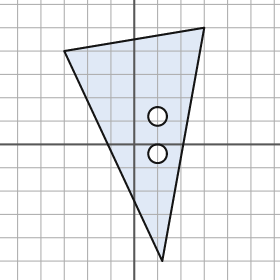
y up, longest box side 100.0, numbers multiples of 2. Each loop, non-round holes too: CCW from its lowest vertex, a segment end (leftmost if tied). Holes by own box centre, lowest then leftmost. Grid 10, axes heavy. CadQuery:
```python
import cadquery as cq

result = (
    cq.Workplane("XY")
    .moveTo(12.0, -50.0)
    .lineTo(30.0, 50.0)
    .lineTo(-30.0, 40.0)
    .close()
    .moveTo(10.0, -4.0)
    .circle(4.0)
    .moveTo(10.0, 12.0)
    .circle(4.0)
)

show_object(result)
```